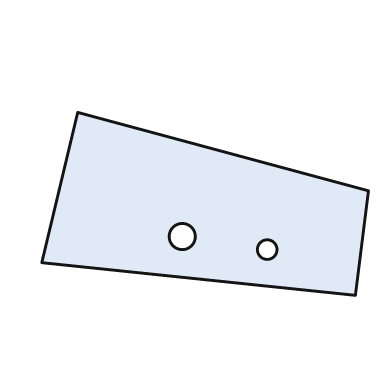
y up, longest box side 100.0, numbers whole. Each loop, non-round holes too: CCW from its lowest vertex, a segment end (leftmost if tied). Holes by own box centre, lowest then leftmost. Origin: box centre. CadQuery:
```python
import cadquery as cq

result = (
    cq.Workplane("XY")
    .moveTo(46.0, -28.0)
    .lineTo(50.0, 4.0)
    .lineTo(-39.0, 28.0)
    .lineTo(-50.0, -18.0)
    .close()
    .moveTo(19.0, -14.0)
    .circle(3.0)
    .moveTo(-7.0, -10.0)
    .circle(4.0)
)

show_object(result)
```